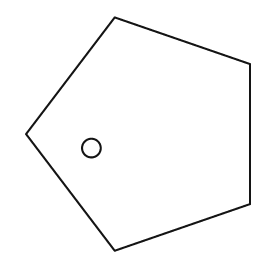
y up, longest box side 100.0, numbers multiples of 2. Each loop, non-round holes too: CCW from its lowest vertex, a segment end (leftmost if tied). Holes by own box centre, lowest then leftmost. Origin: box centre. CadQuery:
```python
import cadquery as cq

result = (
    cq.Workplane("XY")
    .moveTo(-10.0, -50.0)
    .lineTo(48.0, -30.0)
    .lineTo(48.0, 30.0)
    .lineTo(-10.0, 50.0)
    .lineTo(-48.0, 0.0)
    .close()
    .moveTo(-20.0, -6.0)
    .circle(4.0)
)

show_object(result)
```